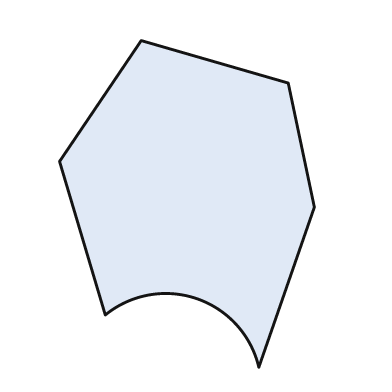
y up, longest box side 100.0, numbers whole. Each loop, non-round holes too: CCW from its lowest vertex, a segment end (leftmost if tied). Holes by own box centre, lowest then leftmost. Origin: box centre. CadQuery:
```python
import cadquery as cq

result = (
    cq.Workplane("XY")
    .moveTo(22.0, -50.0)
    .lineTo(39.0, -1.0)
    .lineTo(31.0, 37.0)
    .lineTo(-14.0, 50.0)
    .lineTo(-39.0, 13.0)
    .lineTo(-25.0, -34.0)
    .threePointArc((3.0, -29.0), (22.0, -50.0))
    .close()
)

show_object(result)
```